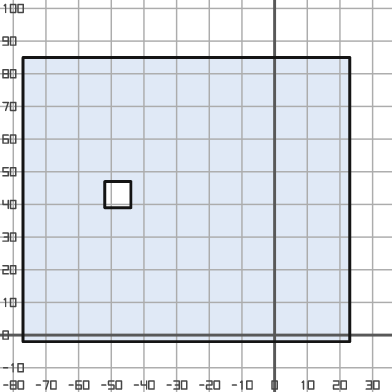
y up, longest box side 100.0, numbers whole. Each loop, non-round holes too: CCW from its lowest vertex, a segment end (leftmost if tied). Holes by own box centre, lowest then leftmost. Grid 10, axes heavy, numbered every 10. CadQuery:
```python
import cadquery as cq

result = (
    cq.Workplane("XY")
    .moveTo(-77.0, -2.0)
    .lineTo(23.0, -2.0)
    .lineTo(23.0, 85.0)
    .lineTo(-77.0, 85.0)
    .close()
    .moveTo(-52.0, 39.0)
    .lineTo(-44.0, 39.0)
    .lineTo(-44.0, 47.0)
    .lineTo(-52.0, 47.0)
    .close()
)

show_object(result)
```